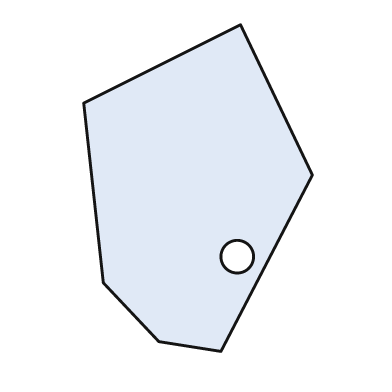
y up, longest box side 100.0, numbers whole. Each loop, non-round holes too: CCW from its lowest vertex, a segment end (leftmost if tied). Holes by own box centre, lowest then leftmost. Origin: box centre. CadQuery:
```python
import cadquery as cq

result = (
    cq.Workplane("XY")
    .moveTo(7.0, -50.0)
    .lineTo(35.0, 4.0)
    .lineTo(13.0, 50.0)
    .lineTo(-35.0, 26.0)
    .lineTo(-29.0, -29.0)
    .lineTo(-12.0, -47.0)
    .close()
    .moveTo(12.0, -21.0)
    .circle(5.0)
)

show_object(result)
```